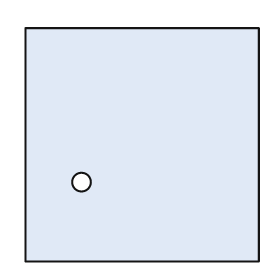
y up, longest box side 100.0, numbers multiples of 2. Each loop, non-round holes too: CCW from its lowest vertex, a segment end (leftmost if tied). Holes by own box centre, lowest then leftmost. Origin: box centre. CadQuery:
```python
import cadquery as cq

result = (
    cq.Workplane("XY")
    .moveTo(-50.0, -50.0)
    .lineTo(50.0, -50.0)
    .lineTo(50.0, 50.0)
    .lineTo(-50.0, 50.0)
    .close()
    .moveTo(-26.0, -16.0)
    .circle(4.0)
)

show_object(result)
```